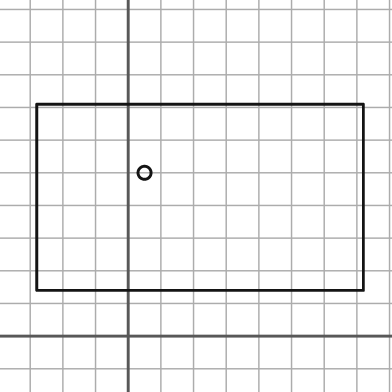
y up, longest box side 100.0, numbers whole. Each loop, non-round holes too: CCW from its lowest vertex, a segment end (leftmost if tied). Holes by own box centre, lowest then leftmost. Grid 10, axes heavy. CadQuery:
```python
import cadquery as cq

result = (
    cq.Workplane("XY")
    .moveTo(-28.0, 14.0)
    .lineTo(72.0, 14.0)
    .lineTo(72.0, 71.0)
    .lineTo(-28.0, 71.0)
    .close()
    .moveTo(5.0, 50.0)
    .circle(2.0)
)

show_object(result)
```